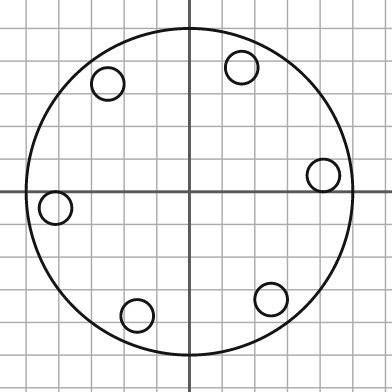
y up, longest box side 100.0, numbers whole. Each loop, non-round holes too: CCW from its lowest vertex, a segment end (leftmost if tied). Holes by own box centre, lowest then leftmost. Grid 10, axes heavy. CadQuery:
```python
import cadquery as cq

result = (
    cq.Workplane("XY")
    .moveTo(0.0, 0.0)
    .circle(50.0)
    .moveTo(-16.0, -38.0)
    .circle(5.0)
    .moveTo(25.0, -33.0)
    .circle(5.0)
    .moveTo(-41.0, -5.0)
    .circle(5.0)
    .moveTo(41.0, 5.0)
    .circle(5.0)
    .moveTo(-25.0, 33.0)
    .circle(5.0)
    .moveTo(16.0, 38.0)
    .circle(5.0)
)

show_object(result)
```